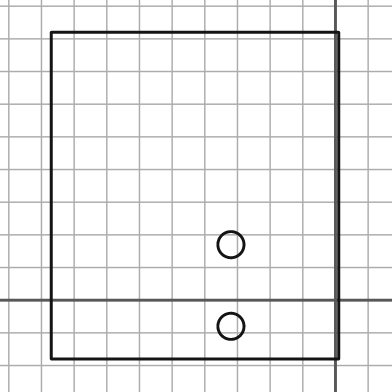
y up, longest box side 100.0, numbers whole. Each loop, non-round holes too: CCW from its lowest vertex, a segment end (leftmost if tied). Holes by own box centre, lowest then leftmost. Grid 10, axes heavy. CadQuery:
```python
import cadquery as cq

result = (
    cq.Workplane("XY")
    .moveTo(-87.0, -18.0)
    .lineTo(1.0, -18.0)
    .lineTo(1.0, 82.0)
    .lineTo(-87.0, 82.0)
    .close()
    .moveTo(-32.0, -8.0)
    .circle(4.0)
    .moveTo(-32.0, 17.0)
    .circle(4.0)
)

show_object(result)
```